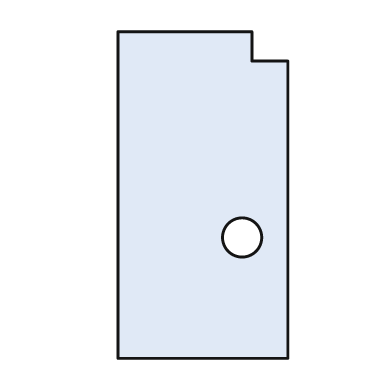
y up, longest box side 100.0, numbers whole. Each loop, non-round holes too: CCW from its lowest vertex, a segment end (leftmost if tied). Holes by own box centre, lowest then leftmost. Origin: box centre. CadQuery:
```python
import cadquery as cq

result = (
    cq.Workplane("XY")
    .moveTo(-26.0, -50.0)
    .lineTo(26.0, -50.0)
    .lineTo(26.0, 41.0)
    .lineTo(15.0, 41.0)
    .lineTo(15.0, 50.0)
    .lineTo(-26.0, 50.0)
    .close()
    .moveTo(12.0, -13.0)
    .circle(6.0)
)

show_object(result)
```